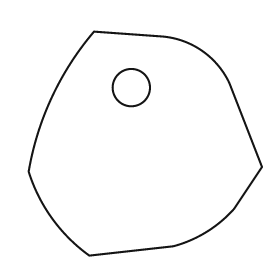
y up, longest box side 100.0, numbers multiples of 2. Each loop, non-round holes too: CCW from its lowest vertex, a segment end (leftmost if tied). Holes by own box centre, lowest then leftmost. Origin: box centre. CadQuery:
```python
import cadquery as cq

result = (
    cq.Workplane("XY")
    .moveTo(-24.0, -48.0)
    .lineTo(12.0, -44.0)
    .threePointArc((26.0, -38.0), (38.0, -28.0))
    .lineTo(50.0, -10.0)
    .lineTo(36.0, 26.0)
    .threePointArc((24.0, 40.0), (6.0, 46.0))
    .lineTo(-22.0, 48.0)
    .threePointArc((-40.0, 20.0), (-50.0, -12.0))
    .threePointArc((-40.0, -32.0), (-24.0, -48.0))
    .close()
    .moveTo(-6.0, 24.0)
    .circle(8.0)
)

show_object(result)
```